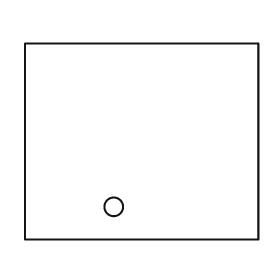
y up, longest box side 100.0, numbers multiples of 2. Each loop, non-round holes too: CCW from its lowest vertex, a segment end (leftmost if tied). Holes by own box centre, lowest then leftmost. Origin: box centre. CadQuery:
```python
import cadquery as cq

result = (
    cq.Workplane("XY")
    .moveTo(-50.0, -42.0)
    .lineTo(50.0, -42.0)
    .lineTo(50.0, 42.0)
    .lineTo(-50.0, 42.0)
    .close()
    .moveTo(-12.0, -28.0)
    .circle(4.0)
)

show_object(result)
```